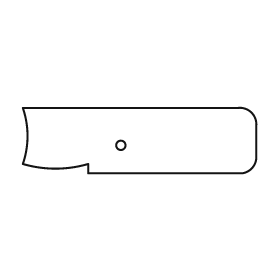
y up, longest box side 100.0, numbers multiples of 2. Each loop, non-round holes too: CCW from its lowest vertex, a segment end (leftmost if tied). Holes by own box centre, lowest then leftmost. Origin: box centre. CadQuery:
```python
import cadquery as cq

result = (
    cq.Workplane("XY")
    .moveTo(-22.0, -14.0)
    .lineTo(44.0, -14.0)
    .threePointArc((48.0, -12.0), (50.0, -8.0))
    .lineTo(50.0, 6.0)
    .threePointArc((48.0, 12.0), (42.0, 14.0))
    .lineTo(-50.0, 14.0)
    .threePointArc((-48.0, 2.0), (-50.0, -10.0))
    .threePointArc((-36.0, -12.0), (-22.0, -10.0))
    .close()
    .moveTo(-8.0, -2.0)
    .circle(2.0)
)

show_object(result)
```